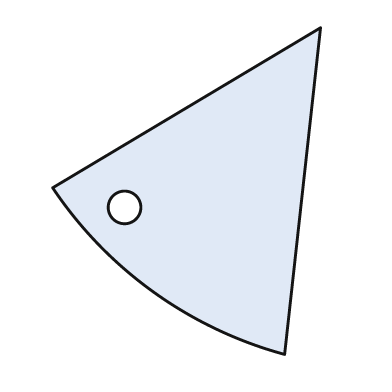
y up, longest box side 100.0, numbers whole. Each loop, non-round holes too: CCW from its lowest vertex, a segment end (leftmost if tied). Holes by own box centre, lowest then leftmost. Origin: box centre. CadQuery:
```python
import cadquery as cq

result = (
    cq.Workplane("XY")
    .moveTo(30.0, -50.0)
    .lineTo(41.0, 50.0)
    .lineTo(-41.0, 1.0)
    .threePointArc((-10.0, -31.0), (30.0, -50.0))
    .close()
    .moveTo(-19.0, -5.0)
    .circle(5.0)
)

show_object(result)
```